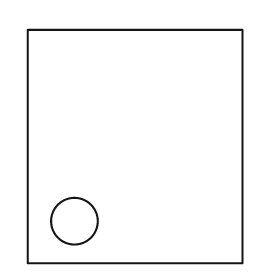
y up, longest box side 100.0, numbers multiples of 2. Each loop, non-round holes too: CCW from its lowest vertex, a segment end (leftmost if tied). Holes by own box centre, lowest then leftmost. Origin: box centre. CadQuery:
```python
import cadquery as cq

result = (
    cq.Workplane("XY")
    .moveTo(-46.0, -50.0)
    .lineTo(46.0, -50.0)
    .lineTo(46.0, 50.0)
    .lineTo(-46.0, 50.0)
    .close()
    .moveTo(-26.0, -32.0)
    .circle(10.0)
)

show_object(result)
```